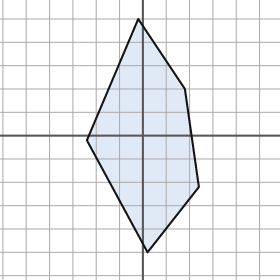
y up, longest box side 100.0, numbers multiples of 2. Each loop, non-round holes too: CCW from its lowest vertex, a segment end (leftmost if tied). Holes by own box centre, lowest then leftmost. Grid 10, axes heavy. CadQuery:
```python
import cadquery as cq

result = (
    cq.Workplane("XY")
    .moveTo(2.0, -50.0)
    .lineTo(24.0, -22.0)
    .lineTo(18.0, 20.0)
    .lineTo(-2.0, 50.0)
    .lineTo(-24.0, -2.0)
    .close()
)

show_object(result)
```